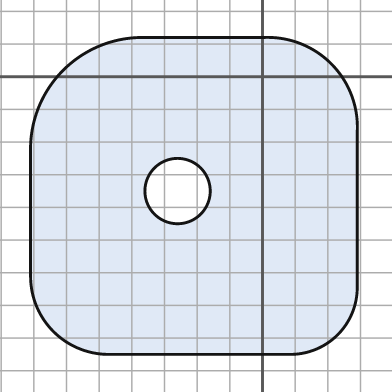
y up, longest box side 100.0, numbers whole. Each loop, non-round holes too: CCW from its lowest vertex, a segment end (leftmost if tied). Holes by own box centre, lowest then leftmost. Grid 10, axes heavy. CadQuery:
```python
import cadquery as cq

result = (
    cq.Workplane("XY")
    .moveTo(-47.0, -85.0)
    .lineTo(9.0, -85.0)
    .threePointArc((23.0, -79.0), (29.0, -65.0))
    .lineTo(29.0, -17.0)
    .threePointArc((21.0, 4.0), (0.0, 12.0))
    .lineTo(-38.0, 12.0)
    .threePointArc((-61.0, 2.0), (-71.0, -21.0))
    .lineTo(-71.0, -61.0)
    .threePointArc((-64.0, -78.0), (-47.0, -85.0))
    .close()
    .moveTo(-26.0, -35.0)
    .circle(10.0)
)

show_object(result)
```